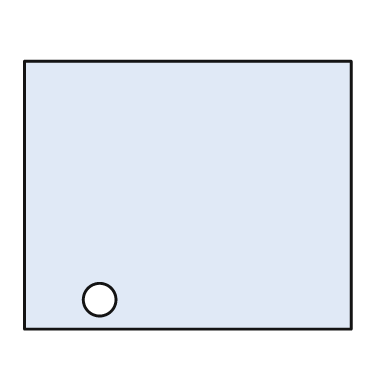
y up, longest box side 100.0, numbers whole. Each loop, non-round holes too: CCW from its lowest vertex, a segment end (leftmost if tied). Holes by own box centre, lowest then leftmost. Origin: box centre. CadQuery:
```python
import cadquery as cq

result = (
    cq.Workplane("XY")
    .moveTo(-50.0, -41.0)
    .lineTo(50.0, -41.0)
    .lineTo(50.0, 41.0)
    .lineTo(-50.0, 41.0)
    .close()
    .moveTo(-27.0, -32.0)
    .circle(5.0)
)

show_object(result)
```